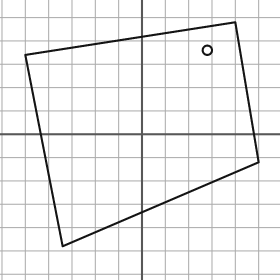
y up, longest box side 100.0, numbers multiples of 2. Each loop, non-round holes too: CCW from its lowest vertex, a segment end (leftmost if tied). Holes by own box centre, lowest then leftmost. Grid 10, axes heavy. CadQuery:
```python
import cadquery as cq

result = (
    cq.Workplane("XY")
    .moveTo(-34.0, -48.0)
    .lineTo(50.0, -12.0)
    .lineTo(40.0, 48.0)
    .lineTo(-50.0, 34.0)
    .close()
    .moveTo(28.0, 36.0)
    .circle(2.0)
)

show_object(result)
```